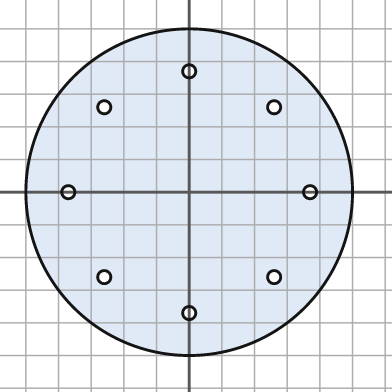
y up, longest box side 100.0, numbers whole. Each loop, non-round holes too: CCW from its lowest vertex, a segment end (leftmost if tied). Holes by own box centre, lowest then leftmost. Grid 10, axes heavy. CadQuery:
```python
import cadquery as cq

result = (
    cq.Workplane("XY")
    .moveTo(0.0, 0.0)
    .circle(50.0)
    .moveTo(0.0, -37.0)
    .circle(2.0)
    .moveTo(-26.0, -26.0)
    .circle(2.0)
    .moveTo(26.0, -26.0)
    .circle(2.0)
    .moveTo(-37.0, 0.0)
    .circle(2.0)
    .moveTo(37.0, 0.0)
    .circle(2.0)
    .moveTo(-26.0, 26.0)
    .circle(2.0)
    .moveTo(26.0, 26.0)
    .circle(2.0)
    .moveTo(0.0, 37.0)
    .circle(2.0)
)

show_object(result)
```